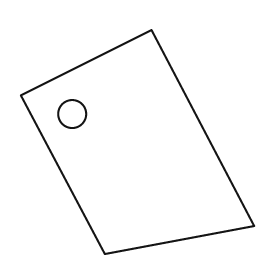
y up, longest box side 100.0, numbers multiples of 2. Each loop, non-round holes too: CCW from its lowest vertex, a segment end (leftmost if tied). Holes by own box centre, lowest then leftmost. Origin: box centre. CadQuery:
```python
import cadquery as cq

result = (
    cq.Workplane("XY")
    .moveTo(-14.0, -48.0)
    .lineTo(50.0, -36.0)
    .lineTo(6.0, 48.0)
    .lineTo(-50.0, 20.0)
    .close()
    .moveTo(-28.0, 12.0)
    .circle(6.0)
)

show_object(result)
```